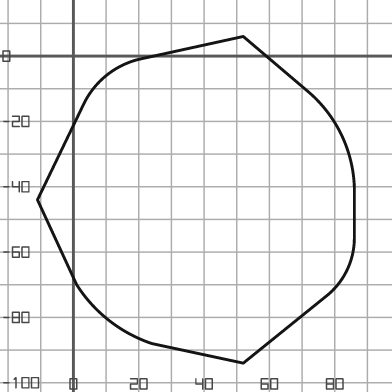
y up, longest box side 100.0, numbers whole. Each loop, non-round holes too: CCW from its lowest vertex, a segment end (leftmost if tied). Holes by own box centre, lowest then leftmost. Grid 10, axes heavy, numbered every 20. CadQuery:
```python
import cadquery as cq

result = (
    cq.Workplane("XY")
    .moveTo(52.0, -94.0)
    .lineTo(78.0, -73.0)
    .threePointArc((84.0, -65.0), (86.0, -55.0))
    .lineTo(86.0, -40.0)
    .threePointArc((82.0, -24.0), (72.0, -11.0))
    .lineTo(52.0, 6.0)
    .lineTo(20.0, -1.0)
    .threePointArc((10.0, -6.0), (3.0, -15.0))
    .lineTo(-11.0, -44.0)
    .lineTo(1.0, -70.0)
    .threePointArc((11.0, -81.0), (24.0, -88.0))
    .close()
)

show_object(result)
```